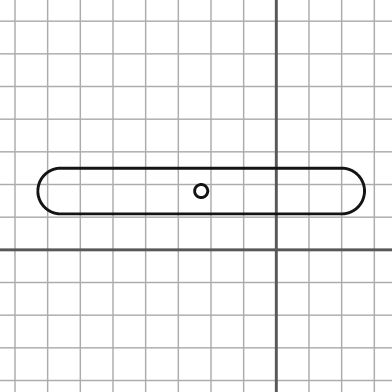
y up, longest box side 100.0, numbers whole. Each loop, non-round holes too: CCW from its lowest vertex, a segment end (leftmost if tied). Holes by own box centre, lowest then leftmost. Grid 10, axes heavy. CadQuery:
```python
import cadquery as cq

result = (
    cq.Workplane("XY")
    .moveTo(-66.0, 11.0)
    .lineTo(20.0, 11.0)
    .threePointArc((27.0, 18.0), (20.0, 25.0))
    .lineTo(-66.0, 25.0)
    .threePointArc((-73.0, 18.0), (-66.0, 11.0))
    .close()
    .moveTo(-23.0, 18.0)
    .circle(2.0)
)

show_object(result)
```